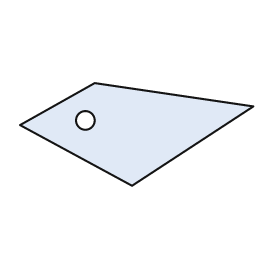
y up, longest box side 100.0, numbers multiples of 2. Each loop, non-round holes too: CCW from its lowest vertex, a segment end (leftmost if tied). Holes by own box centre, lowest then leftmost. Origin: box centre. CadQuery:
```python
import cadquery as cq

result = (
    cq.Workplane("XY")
    .moveTo(-2.0, -22.0)
    .lineTo(50.0, 12.0)
    .lineTo(-18.0, 22.0)
    .lineTo(-50.0, 4.0)
    .close()
    .moveTo(-22.0, 6.0)
    .circle(4.0)
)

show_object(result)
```